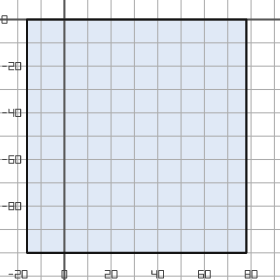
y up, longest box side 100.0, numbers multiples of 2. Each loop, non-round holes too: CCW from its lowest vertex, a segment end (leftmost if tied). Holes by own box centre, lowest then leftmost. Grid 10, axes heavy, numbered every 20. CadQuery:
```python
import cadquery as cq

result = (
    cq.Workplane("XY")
    .moveTo(-16.0, -100.0)
    .lineTo(78.0, -100.0)
    .lineTo(78.0, 0.0)
    .lineTo(-16.0, 0.0)
    .close()
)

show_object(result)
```